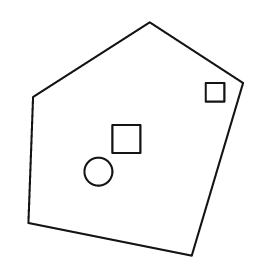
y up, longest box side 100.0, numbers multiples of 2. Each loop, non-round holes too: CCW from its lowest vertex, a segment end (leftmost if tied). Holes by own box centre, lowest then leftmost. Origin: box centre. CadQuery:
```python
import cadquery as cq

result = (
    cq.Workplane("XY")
    .moveTo(24.0, -50.0)
    .lineTo(46.0, 24.0)
    .lineTo(6.0, 50.0)
    .lineTo(-44.0, 18.0)
    .lineTo(-46.0, -36.0)
    .close()
    .moveTo(-16.0, -14.0)
    .circle(6.0)
    .moveTo(-10.0, -6.0)
    .lineTo(2.0, -6.0)
    .lineTo(2.0, 6.0)
    .lineTo(-10.0, 6.0)
    .close()
    .moveTo(30.0, 16.0)
    .lineTo(38.0, 16.0)
    .lineTo(38.0, 24.0)
    .lineTo(30.0, 24.0)
    .close()
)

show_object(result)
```